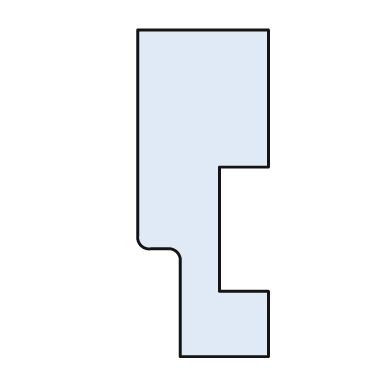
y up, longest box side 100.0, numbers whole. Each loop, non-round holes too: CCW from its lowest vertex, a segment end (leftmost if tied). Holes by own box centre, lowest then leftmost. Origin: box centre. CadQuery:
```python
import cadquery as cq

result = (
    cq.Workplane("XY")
    .moveTo(-7.0, -50.0)
    .lineTo(20.0, -50.0)
    .lineTo(20.0, -30.0)
    .lineTo(5.0, -30.0)
    .lineTo(5.0, 8.0)
    .lineTo(20.0, 8.0)
    .lineTo(20.0, 50.0)
    .lineTo(-20.0, 50.0)
    .lineTo(-20.0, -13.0)
    .threePointArc((-19.0, -16.0), (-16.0, -17.0))
    .lineTo(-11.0, -17.0)
    .threePointArc((-8.0, -18.0), (-7.0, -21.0))
    .close()
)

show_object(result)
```